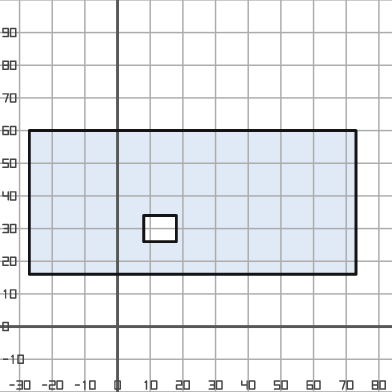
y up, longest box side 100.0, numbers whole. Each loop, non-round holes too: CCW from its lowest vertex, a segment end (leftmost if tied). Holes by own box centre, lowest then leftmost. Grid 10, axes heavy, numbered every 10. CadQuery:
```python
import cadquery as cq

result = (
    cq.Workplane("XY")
    .moveTo(-27.0, 16.0)
    .lineTo(73.0, 16.0)
    .lineTo(73.0, 60.0)
    .lineTo(-27.0, 60.0)
    .close()
    .moveTo(8.0, 26.0)
    .lineTo(18.0, 26.0)
    .lineTo(18.0, 34.0)
    .lineTo(8.0, 34.0)
    .close()
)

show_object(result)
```